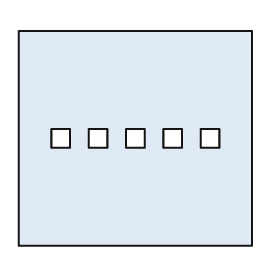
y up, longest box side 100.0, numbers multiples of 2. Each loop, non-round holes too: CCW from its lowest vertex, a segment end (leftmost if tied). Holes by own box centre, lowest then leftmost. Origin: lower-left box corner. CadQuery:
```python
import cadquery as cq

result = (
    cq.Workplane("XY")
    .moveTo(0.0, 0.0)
    .lineTo(100.0, 0.0)
    .lineTo(100.0, 92.0)
    .lineTo(0.0, 92.0)
    .close()
    .moveTo(14.0, 42.0)
    .lineTo(22.0, 42.0)
    .lineTo(22.0, 50.0)
    .lineTo(14.0, 50.0)
    .close()
    .moveTo(30.0, 42.0)
    .lineTo(38.0, 42.0)
    .lineTo(38.0, 50.0)
    .lineTo(30.0, 50.0)
    .close()
    .moveTo(46.0, 42.0)
    .lineTo(54.0, 42.0)
    .lineTo(54.0, 50.0)
    .lineTo(46.0, 50.0)
    .close()
    .moveTo(62.0, 42.0)
    .lineTo(70.0, 42.0)
    .lineTo(70.0, 50.0)
    .lineTo(62.0, 50.0)
    .close()
    .moveTo(78.0, 42.0)
    .lineTo(86.0, 42.0)
    .lineTo(86.0, 50.0)
    .lineTo(78.0, 50.0)
    .close()
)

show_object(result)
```